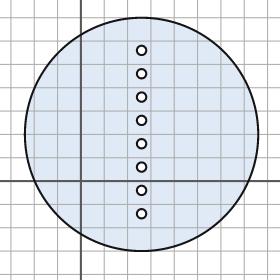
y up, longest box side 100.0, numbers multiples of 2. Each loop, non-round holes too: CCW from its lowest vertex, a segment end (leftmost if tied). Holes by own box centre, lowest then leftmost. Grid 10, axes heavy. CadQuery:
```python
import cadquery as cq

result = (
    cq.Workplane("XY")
    .moveTo(26.0, 20.0)
    .circle(50.0)
    .moveTo(26.0, -14.0)
    .circle(2.0)
    .moveTo(26.0, -4.0)
    .circle(2.0)
    .moveTo(26.0, 6.0)
    .circle(2.0)
    .moveTo(26.0, 16.0)
    .circle(2.0)
    .moveTo(26.0, 26.0)
    .circle(2.0)
    .moveTo(26.0, 36.0)
    .circle(2.0)
    .moveTo(26.0, 46.0)
    .circle(2.0)
    .moveTo(26.0, 56.0)
    .circle(2.0)
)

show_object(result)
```